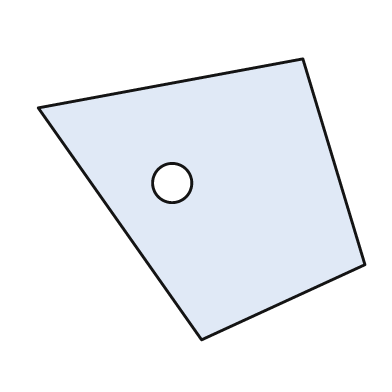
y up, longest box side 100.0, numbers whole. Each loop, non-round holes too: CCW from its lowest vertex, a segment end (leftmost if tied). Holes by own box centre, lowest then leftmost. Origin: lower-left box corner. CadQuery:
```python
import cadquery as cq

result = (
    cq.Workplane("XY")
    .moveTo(50.0, 0.0)
    .lineTo(100.0, 23.0)
    .lineTo(81.0, 86.0)
    .lineTo(0.0, 71.0)
    .close()
    .moveTo(41.0, 48.0)
    .circle(6.0)
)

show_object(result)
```